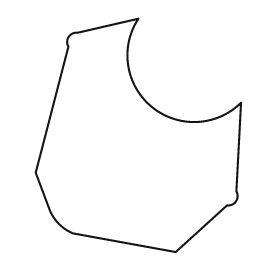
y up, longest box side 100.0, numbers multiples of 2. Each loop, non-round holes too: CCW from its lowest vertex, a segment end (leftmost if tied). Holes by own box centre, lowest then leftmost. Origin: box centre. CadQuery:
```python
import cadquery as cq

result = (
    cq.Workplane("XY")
    .moveTo(16.0, -50.0)
    .lineTo(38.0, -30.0)
    .threePointArc((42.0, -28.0), (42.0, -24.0))
    .lineTo(44.0, 14.0)
    .threePointArc((6.0, 12.0), (0.0, 50.0))
    .lineTo(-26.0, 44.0)
    .threePointArc((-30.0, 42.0), (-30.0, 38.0))
    .lineTo(-44.0, -16.0)
    .lineTo(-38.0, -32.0)
    .threePointArc((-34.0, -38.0), (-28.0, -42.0))
    .close()
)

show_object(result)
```